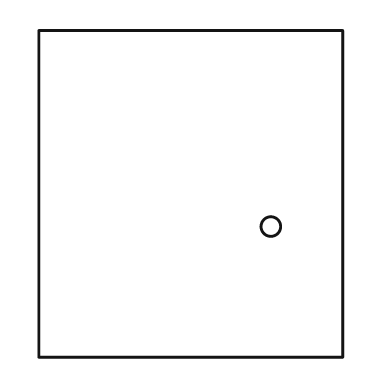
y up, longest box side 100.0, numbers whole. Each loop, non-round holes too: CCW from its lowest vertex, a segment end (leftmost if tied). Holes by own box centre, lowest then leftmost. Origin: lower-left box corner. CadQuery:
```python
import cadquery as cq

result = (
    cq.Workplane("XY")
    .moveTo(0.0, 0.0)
    .lineTo(93.0, 0.0)
    .lineTo(93.0, 100.0)
    .lineTo(0.0, 100.0)
    .close()
    .moveTo(71.0, 40.0)
    .circle(3.0)
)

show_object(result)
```